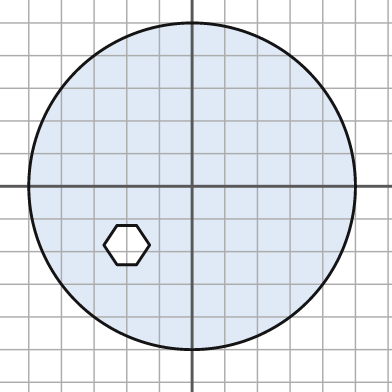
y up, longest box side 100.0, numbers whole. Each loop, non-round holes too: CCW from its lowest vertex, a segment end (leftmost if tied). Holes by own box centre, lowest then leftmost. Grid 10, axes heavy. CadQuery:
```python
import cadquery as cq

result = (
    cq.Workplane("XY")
    .moveTo(0.0, 0.0)
    .circle(50.0)
    .moveTo(-23.0, -24.0)
    .lineTo(-17.0, -24.0)
    .lineTo(-13.0, -18.0)
    .lineTo(-17.0, -12.0)
    .lineTo(-23.0, -12.0)
    .lineTo(-27.0, -18.0)
    .close()
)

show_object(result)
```